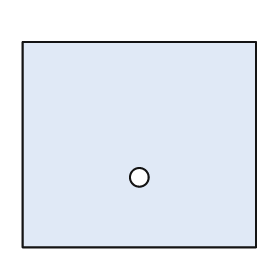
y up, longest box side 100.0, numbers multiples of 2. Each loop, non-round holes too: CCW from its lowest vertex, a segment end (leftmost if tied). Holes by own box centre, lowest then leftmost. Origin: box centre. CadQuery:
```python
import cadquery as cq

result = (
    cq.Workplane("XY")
    .moveTo(-50.0, -44.0)
    .lineTo(50.0, -44.0)
    .lineTo(50.0, 44.0)
    .lineTo(-50.0, 44.0)
    .close()
    .moveTo(0.0, -14.0)
    .circle(4.0)
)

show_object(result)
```